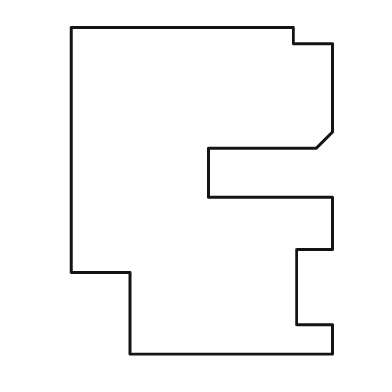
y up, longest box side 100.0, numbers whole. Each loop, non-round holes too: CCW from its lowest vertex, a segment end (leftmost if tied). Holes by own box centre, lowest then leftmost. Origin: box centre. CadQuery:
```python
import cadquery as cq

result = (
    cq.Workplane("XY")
    .moveTo(-22.0, -50.0)
    .lineTo(40.0, -50.0)
    .lineTo(40.0, -41.0)
    .lineTo(29.0, -41.0)
    .lineTo(29.0, -18.0)
    .lineTo(40.0, -18.0)
    .lineTo(40.0, -2.0)
    .lineTo(2.0, -2.0)
    .lineTo(2.0, 13.0)
    .lineTo(35.0, 13.0)
    .lineTo(40.0, 18.0)
    .lineTo(40.0, 45.0)
    .lineTo(28.0, 45.0)
    .lineTo(28.0, 50.0)
    .lineTo(-40.0, 50.0)
    .lineTo(-40.0, -25.0)
    .lineTo(-22.0, -25.0)
    .close()
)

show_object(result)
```